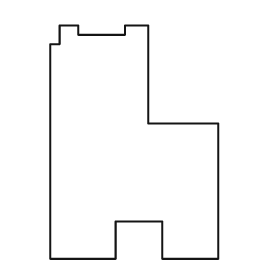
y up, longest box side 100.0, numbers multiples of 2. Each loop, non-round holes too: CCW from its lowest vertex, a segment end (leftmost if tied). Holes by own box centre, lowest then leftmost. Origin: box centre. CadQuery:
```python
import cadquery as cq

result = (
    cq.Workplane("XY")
    .moveTo(-36.0, -50.0)
    .lineTo(-8.0, -50.0)
    .lineTo(-8.0, -34.0)
    .lineTo(12.0, -34.0)
    .lineTo(12.0, -50.0)
    .lineTo(36.0, -50.0)
    .lineTo(36.0, 8.0)
    .lineTo(6.0, 8.0)
    .lineTo(6.0, 50.0)
    .lineTo(-4.0, 50.0)
    .lineTo(-4.0, 46.0)
    .lineTo(-24.0, 46.0)
    .lineTo(-24.0, 50.0)
    .lineTo(-32.0, 50.0)
    .lineTo(-32.0, 42.0)
    .lineTo(-36.0, 42.0)
    .close()
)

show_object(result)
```